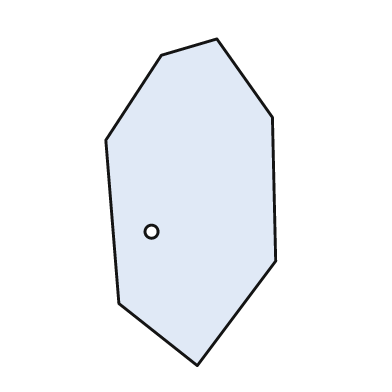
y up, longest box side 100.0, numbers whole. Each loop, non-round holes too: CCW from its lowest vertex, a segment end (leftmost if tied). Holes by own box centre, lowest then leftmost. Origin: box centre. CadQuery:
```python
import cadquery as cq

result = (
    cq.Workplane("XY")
    .moveTo(2.0, -50.0)
    .lineTo(26.0, -18.0)
    .lineTo(25.0, 26.0)
    .lineTo(8.0, 50.0)
    .lineTo(-9.0, 45.0)
    .lineTo(-26.0, 19.0)
    .lineTo(-22.0, -31.0)
    .close()
    .moveTo(-12.0, -9.0)
    .circle(2.0)
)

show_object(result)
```